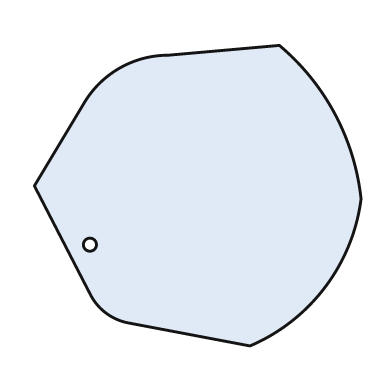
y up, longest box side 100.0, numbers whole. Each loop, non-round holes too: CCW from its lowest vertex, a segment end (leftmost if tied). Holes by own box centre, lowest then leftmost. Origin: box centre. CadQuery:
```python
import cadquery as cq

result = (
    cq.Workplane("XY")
    .moveTo(16.0, -46.0)
    .threePointArc((39.0, -28.0), (50.0, -1.0))
    .threePointArc((42.0, 25.0), (25.0, 46.0))
    .lineTo(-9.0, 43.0)
    .threePointArc((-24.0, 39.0), (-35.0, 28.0))
    .lineTo(-50.0, 3.0)
    .lineTo(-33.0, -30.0)
    .threePointArc((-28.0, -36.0), (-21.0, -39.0))
    .close()
    .moveTo(-33.0, -15.0)
    .circle(2.0)
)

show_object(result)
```